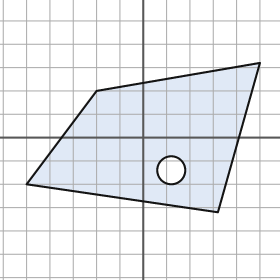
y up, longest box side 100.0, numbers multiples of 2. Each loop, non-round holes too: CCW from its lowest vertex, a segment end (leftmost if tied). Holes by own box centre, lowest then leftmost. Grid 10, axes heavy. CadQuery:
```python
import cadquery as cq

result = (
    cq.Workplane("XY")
    .moveTo(32.0, -32.0)
    .lineTo(50.0, 32.0)
    .lineTo(-20.0, 20.0)
    .lineTo(-50.0, -20.0)
    .close()
    .moveTo(12.0, -14.0)
    .circle(6.0)
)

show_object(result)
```